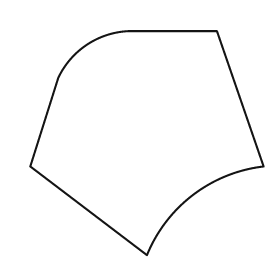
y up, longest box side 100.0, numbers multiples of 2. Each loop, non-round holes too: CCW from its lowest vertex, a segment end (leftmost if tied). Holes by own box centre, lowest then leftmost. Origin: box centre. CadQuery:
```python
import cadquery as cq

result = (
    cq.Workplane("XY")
    .moveTo(0.0, -48.0)
    .threePointArc((20.0, -22.0), (50.0, -10.0))
    .lineTo(30.0, 48.0)
    .lineTo(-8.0, 48.0)
    .threePointArc((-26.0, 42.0), (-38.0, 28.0))
    .lineTo(-50.0, -10.0)
    .close()
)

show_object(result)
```